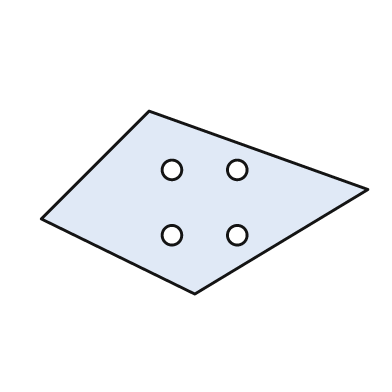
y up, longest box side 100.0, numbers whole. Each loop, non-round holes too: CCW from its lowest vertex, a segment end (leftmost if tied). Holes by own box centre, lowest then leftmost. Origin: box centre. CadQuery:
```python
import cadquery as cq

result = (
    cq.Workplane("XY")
    .moveTo(-3.0, -28.0)
    .lineTo(50.0, 4.0)
    .lineTo(-17.0, 28.0)
    .lineTo(-50.0, -5.0)
    .close()
    .moveTo(-10.0, -10.0)
    .circle(3.0)
    .moveTo(10.0, -10.0)
    .circle(3.0)
    .moveTo(-10.0, 10.0)
    .circle(3.0)
    .moveTo(10.0, 10.0)
    .circle(3.0)
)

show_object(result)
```